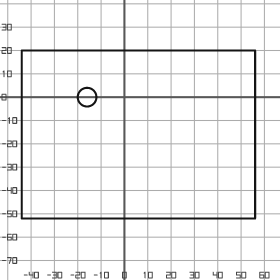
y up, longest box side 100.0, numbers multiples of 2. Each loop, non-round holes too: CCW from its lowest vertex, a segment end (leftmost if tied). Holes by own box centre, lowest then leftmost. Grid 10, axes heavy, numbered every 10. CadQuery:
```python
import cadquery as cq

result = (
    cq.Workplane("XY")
    .moveTo(-44.0, -52.0)
    .lineTo(56.0, -52.0)
    .lineTo(56.0, 20.0)
    .lineTo(-44.0, 20.0)
    .close()
    .moveTo(-16.0, 0.0)
    .circle(4.0)
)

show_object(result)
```